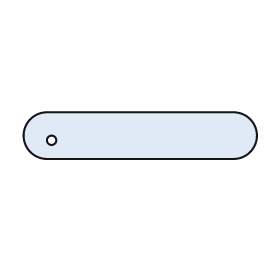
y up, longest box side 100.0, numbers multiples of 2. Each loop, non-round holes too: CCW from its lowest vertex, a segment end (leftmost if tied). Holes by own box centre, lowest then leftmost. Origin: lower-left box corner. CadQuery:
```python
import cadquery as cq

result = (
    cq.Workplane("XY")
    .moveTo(10.0, 0.0)
    .lineTo(90.0, 0.0)
    .threePointArc((100.0, 10.0), (90.0, 20.0))
    .lineTo(10.0, 20.0)
    .threePointArc((0.0, 10.0), (10.0, 0.0))
    .close()
    .moveTo(12.0, 8.0)
    .circle(2.0)
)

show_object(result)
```